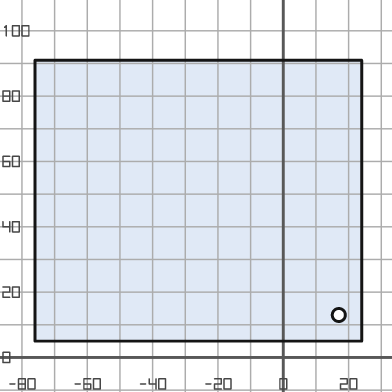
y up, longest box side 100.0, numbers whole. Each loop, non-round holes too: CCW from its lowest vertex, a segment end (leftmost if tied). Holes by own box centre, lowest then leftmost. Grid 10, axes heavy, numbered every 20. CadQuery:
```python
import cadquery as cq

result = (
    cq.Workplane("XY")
    .moveTo(-76.0, 5.0)
    .lineTo(24.0, 5.0)
    .lineTo(24.0, 91.0)
    .lineTo(-76.0, 91.0)
    .close()
    .moveTo(17.0, 13.0)
    .circle(2.0)
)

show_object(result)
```